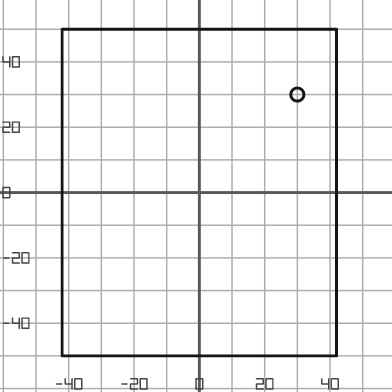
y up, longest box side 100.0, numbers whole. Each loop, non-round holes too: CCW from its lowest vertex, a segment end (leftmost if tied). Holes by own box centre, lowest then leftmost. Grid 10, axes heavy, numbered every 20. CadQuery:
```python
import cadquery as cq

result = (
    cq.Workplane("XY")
    .moveTo(-42.0, -50.0)
    .lineTo(42.0, -50.0)
    .lineTo(42.0, 50.0)
    .lineTo(-42.0, 50.0)
    .close()
    .moveTo(30.0, 30.0)
    .circle(2.0)
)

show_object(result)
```